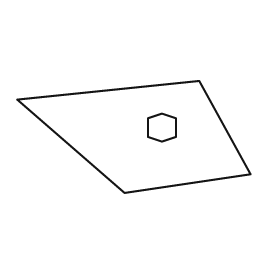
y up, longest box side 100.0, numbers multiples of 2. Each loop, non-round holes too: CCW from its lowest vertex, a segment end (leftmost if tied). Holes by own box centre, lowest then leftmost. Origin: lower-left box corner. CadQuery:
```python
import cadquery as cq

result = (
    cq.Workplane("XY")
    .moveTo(46.0, 0.0)
    .lineTo(100.0, 8.0)
    .lineTo(78.0, 48.0)
    .lineTo(0.0, 40.0)
    .close()
    .moveTo(62.0, 22.0)
    .lineTo(68.0, 24.0)
    .lineTo(68.0, 32.0)
    .lineTo(62.0, 34.0)
    .lineTo(56.0, 32.0)
    .lineTo(56.0, 24.0)
    .close()
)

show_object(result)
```